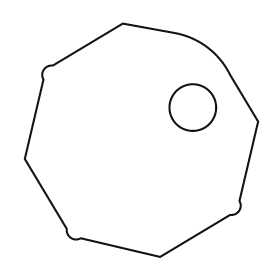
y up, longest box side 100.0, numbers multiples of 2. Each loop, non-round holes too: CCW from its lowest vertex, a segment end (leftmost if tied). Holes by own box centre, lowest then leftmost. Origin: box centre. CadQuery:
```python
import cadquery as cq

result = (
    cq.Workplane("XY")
    .moveTo(8.0, -50.0)
    .lineTo(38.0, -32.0)
    .threePointArc((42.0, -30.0), (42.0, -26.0))
    .lineTo(50.0, 8.0)
    .lineTo(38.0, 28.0)
    .threePointArc((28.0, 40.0), (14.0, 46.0))
    .lineTo(-8.0, 50.0)
    .lineTo(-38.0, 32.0)
    .threePointArc((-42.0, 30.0), (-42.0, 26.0))
    .lineTo(-50.0, -8.0)
    .lineTo(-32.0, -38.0)
    .threePointArc((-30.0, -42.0), (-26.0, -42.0))
    .close()
    .moveTo(22.0, 14.0)
    .circle(10.0)
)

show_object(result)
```